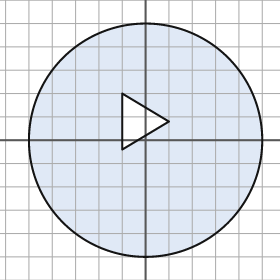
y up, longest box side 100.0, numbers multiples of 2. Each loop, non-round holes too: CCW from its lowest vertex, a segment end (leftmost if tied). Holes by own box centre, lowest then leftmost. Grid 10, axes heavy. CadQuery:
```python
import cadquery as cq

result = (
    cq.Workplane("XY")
    .moveTo(0.0, 0.0)
    .circle(50.0)
    .moveTo(-10.0, -4.0)
    .lineTo(10.0, 8.0)
    .lineTo(-10.0, 20.0)
    .close()
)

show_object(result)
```